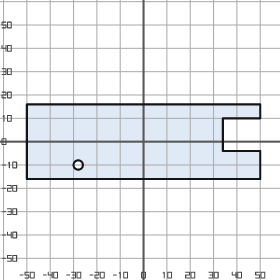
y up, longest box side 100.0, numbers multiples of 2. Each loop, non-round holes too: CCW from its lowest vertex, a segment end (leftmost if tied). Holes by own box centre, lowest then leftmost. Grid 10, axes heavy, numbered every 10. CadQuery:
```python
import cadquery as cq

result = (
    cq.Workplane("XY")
    .moveTo(-50.0, -16.0)
    .lineTo(50.0, -16.0)
    .lineTo(50.0, -4.0)
    .lineTo(34.0, -4.0)
    .lineTo(34.0, 10.0)
    .lineTo(50.0, 10.0)
    .lineTo(50.0, 16.0)
    .lineTo(-50.0, 16.0)
    .close()
    .moveTo(-28.0, -10.0)
    .circle(2.0)
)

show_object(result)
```